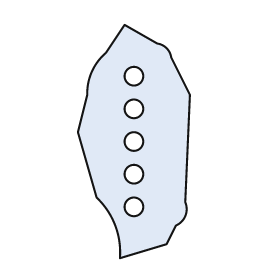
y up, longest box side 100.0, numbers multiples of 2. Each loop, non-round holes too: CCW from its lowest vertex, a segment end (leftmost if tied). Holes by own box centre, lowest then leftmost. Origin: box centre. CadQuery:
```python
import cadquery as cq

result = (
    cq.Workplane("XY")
    .moveTo(-6.0, -50.0)
    .lineTo(14.0, -44.0)
    .lineTo(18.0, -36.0)
    .threePointArc((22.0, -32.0), (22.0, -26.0))
    .lineTo(24.0, 20.0)
    .lineTo(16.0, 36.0)
    .threePointArc((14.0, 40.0), (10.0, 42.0))
    .lineTo(-4.0, 50.0)
    .lineTo(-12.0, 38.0)
    .threePointArc((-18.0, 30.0), (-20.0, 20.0))
    .lineTo(-24.0, 4.0)
    .lineTo(-16.0, -24.0)
    .threePointArc((-8.0, -36.0), (-6.0, -50.0))
    .close()
    .moveTo(0.0, -28.0)
    .circle(4.0)
    .moveTo(0.0, -14.0)
    .circle(4.0)
    .moveTo(0.0, 0.0)
    .circle(4.0)
    .moveTo(0.0, 14.0)
    .circle(4.0)
    .moveTo(0.0, 28.0)
    .circle(4.0)
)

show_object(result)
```